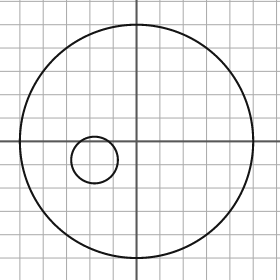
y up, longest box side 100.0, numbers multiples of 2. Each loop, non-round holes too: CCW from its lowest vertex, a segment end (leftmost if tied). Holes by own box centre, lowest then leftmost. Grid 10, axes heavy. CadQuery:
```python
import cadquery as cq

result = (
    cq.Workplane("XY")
    .moveTo(0.0, 0.0)
    .circle(50.0)
    .moveTo(-18.0, -8.0)
    .circle(10.0)
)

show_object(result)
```